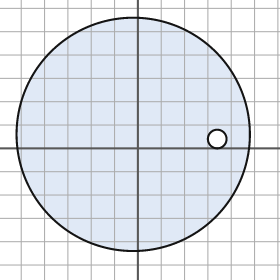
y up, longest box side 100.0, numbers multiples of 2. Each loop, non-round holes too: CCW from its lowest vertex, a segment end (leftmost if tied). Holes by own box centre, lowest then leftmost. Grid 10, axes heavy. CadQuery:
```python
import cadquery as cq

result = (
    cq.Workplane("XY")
    .moveTo(-2.0, 6.0)
    .circle(50.0)
    .moveTo(34.0, 4.0)
    .circle(4.0)
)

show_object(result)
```